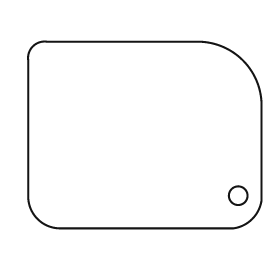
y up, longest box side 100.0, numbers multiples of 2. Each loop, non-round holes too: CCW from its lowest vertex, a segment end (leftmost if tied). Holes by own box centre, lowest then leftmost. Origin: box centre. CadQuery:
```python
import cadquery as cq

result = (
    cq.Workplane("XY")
    .moveTo(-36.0, -40.0)
    .lineTo(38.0, -40.0)
    .threePointArc((46.0, -36.0), (50.0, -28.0))
    .lineTo(50.0, 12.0)
    .threePointArc((42.0, 32.0), (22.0, 40.0))
    .lineTo(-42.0, 40.0)
    .threePointArc((-48.0, 38.0), (-50.0, 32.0))
    .lineTo(-50.0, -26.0)
    .threePointArc((-46.0, -36.0), (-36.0, -40.0))
    .close()
    .moveTo(40.0, -26.0)
    .circle(4.0)
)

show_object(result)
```